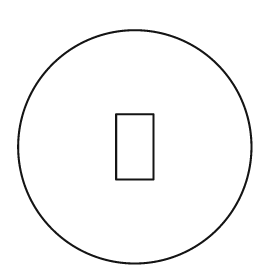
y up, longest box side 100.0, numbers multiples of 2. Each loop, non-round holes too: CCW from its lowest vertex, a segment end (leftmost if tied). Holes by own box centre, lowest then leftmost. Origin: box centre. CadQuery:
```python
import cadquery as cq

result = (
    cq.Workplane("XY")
    .moveTo(0.0, 0.0)
    .circle(50.0)
    .moveTo(-8.0, -14.0)
    .lineTo(8.0, -14.0)
    .lineTo(8.0, 14.0)
    .lineTo(-8.0, 14.0)
    .close()
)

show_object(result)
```